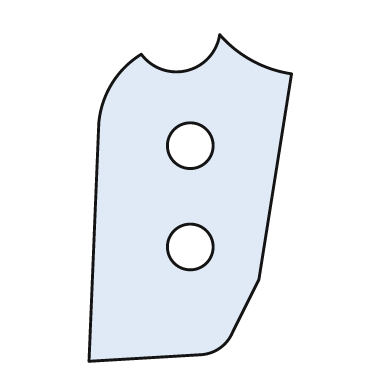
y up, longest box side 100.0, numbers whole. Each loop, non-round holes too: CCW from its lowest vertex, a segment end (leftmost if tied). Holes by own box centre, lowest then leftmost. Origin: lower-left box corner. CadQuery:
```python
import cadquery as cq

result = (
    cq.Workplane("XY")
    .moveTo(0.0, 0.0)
    .lineTo(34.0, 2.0)
    .threePointArc((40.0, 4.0), (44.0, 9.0))
    .lineTo(52.0, 25.0)
    .lineTo(62.0, 88.0)
    .threePointArc((50.0, 92.0), (40.0, 100.0))
    .threePointArc((30.0, 89.0), (16.0, 94.0))
    .threePointArc((7.0, 85.0), (3.0, 73.0))
    .close()
    .moveTo(31.0, 35.0)
    .circle(7.0)
    .moveTo(31.0, 66.0)
    .circle(7.0)
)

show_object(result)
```